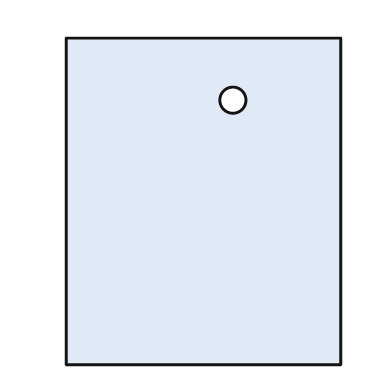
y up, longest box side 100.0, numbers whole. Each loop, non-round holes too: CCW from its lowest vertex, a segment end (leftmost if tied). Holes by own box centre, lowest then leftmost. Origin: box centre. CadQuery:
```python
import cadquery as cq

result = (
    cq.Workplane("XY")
    .moveTo(-42.0, -50.0)
    .lineTo(42.0, -50.0)
    .lineTo(42.0, 50.0)
    .lineTo(-42.0, 50.0)
    .close()
    .moveTo(9.0, 31.0)
    .circle(4.0)
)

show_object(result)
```